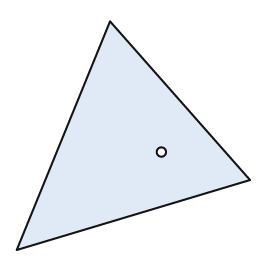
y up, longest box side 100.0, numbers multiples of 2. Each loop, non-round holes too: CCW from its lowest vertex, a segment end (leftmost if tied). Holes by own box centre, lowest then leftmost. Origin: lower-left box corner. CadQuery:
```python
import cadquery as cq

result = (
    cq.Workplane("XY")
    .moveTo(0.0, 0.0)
    .lineTo(100.0, 30.0)
    .lineTo(40.0, 98.0)
    .close()
    .moveTo(62.0, 42.0)
    .circle(2.0)
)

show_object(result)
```